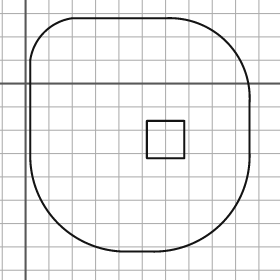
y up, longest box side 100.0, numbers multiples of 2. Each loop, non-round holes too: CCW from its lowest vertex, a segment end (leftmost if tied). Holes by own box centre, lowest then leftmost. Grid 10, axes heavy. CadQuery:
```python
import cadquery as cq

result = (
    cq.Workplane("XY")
    .moveTo(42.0, -72.0)
    .lineTo(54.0, -72.0)
    .threePointArc((84.0, -60.0), (96.0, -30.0))
    .lineTo(96.0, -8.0)
    .threePointArc((86.0, 18.0), (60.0, 28.0))
    .lineTo(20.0, 28.0)
    .threePointArc((8.0, 22.0), (2.0, 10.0))
    .lineTo(2.0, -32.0)
    .threePointArc((14.0, -60.0), (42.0, -72.0))
    .close()
    .moveTo(52.0, -32.0)
    .lineTo(68.0, -32.0)
    .lineTo(68.0, -16.0)
    .lineTo(52.0, -16.0)
    .close()
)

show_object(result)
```